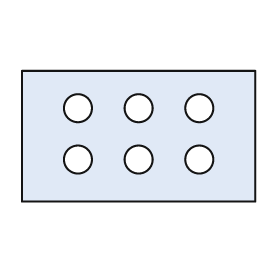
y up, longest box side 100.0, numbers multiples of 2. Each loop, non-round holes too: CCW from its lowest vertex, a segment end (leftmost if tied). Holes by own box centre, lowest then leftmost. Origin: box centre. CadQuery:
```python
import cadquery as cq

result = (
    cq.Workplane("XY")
    .moveTo(-50.0, -28.0)
    .lineTo(50.0, -28.0)
    .lineTo(50.0, 28.0)
    .lineTo(-50.0, 28.0)
    .close()
    .moveTo(-26.0, -10.0)
    .circle(6.0)
    .moveTo(0.0, -10.0)
    .circle(6.0)
    .moveTo(26.0, -10.0)
    .circle(6.0)
    .moveTo(-26.0, 12.0)
    .circle(6.0)
    .moveTo(0.0, 12.0)
    .circle(6.0)
    .moveTo(26.0, 12.0)
    .circle(6.0)
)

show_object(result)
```